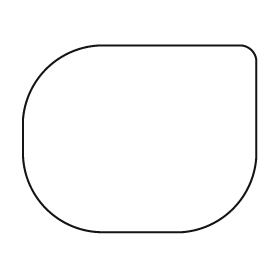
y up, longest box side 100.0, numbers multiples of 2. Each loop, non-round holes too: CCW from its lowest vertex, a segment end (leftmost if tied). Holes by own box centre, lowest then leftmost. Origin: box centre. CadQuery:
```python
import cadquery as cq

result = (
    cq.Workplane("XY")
    .moveTo(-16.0, -40.0)
    .lineTo(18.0, -40.0)
    .threePointArc((40.0, -30.0), (50.0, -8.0))
    .lineTo(50.0, 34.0)
    .threePointArc((48.0, 38.0), (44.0, 40.0))
    .lineTo(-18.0, 40.0)
    .threePointArc((-40.0, 30.0), (-50.0, 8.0))
    .lineTo(-50.0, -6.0)
    .threePointArc((-40.0, -30.0), (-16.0, -40.0))
    .close()
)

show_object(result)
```